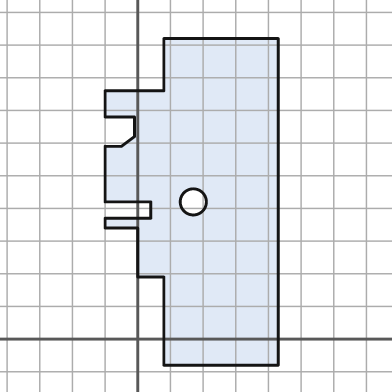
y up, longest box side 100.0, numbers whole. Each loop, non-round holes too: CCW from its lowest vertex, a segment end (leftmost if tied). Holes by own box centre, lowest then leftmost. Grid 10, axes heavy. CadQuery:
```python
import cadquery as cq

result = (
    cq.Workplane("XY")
    .moveTo(8.0, -8.0)
    .lineTo(43.0, -8.0)
    .lineTo(43.0, 92.0)
    .lineTo(8.0, 92.0)
    .lineTo(8.0, 76.0)
    .lineTo(-10.0, 76.0)
    .lineTo(-10.0, 68.0)
    .lineTo(-1.0, 68.0)
    .lineTo(-1.0, 62.0)
    .lineTo(-5.0, 59.0)
    .lineTo(-10.0, 59.0)
    .lineTo(-10.0, 42.0)
    .lineTo(4.0, 42.0)
    .lineTo(4.0, 37.0)
    .lineTo(-10.0, 37.0)
    .lineTo(-10.0, 34.0)
    .lineTo(0.0, 34.0)
    .lineTo(0.0, 19.0)
    .lineTo(8.0, 19.0)
    .close()
    .moveTo(17.0, 42.0)
    .circle(4.0)
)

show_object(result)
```